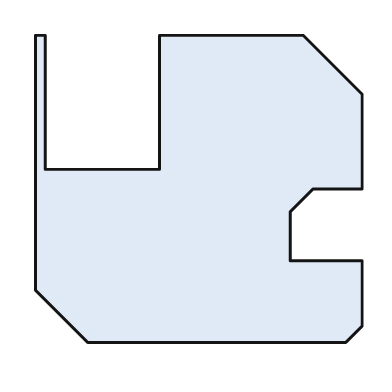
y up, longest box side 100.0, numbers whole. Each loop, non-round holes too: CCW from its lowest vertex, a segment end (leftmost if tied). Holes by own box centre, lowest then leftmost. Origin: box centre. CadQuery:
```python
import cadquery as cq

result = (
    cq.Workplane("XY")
    .moveTo(-34.0, -47.0)
    .lineTo(45.0, -47.0)
    .lineTo(50.0, -42.0)
    .lineTo(50.0, -22.0)
    .lineTo(28.0, -22.0)
    .lineTo(28.0, -7.0)
    .lineTo(35.0, 0.0)
    .lineTo(50.0, 0.0)
    .lineTo(50.0, 29.0)
    .lineTo(32.0, 47.0)
    .lineTo(-12.0, 47.0)
    .lineTo(-12.0, 6.0)
    .lineTo(-47.0, 6.0)
    .lineTo(-47.0, 47.0)
    .lineTo(-50.0, 47.0)
    .lineTo(-50.0, -31.0)
    .close()
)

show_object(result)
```